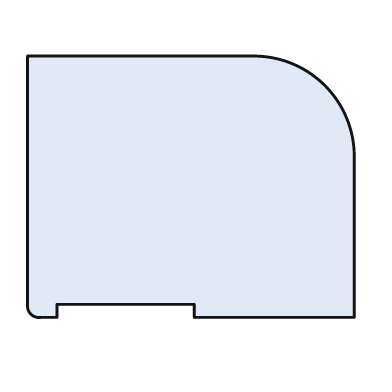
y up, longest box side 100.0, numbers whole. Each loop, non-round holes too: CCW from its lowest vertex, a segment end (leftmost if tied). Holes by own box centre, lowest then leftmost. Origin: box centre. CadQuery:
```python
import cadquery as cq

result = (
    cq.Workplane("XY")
    .moveTo(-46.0, -40.0)
    .lineTo(-41.0, -40.0)
    .lineTo(-41.0, -36.0)
    .lineTo(1.0, -36.0)
    .lineTo(1.0, -40.0)
    .lineTo(50.0, -40.0)
    .lineTo(50.0, 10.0)
    .threePointArc((41.0, 31.0), (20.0, 40.0))
    .lineTo(-50.0, 40.0)
    .lineTo(-50.0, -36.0)
    .threePointArc((-49.0, -39.0), (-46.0, -40.0))
    .close()
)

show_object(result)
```